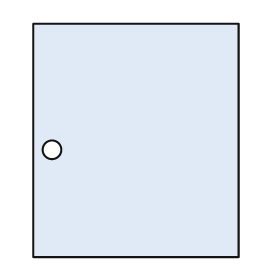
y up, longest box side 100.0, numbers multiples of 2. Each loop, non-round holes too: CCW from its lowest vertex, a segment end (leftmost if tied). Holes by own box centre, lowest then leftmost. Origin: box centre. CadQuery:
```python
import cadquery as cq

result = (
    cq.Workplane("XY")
    .moveTo(-44.0, -50.0)
    .lineTo(44.0, -50.0)
    .lineTo(44.0, 50.0)
    .lineTo(-44.0, 50.0)
    .close()
    .moveTo(-36.0, -4.0)
    .circle(4.0)
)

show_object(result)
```